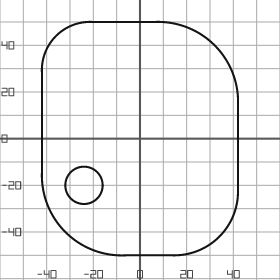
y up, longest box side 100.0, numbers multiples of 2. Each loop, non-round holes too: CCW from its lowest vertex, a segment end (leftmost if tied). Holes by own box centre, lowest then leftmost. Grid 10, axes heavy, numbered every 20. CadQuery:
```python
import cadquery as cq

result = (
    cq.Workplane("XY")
    .moveTo(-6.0, -50.0)
    .lineTo(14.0, -50.0)
    .threePointArc((34.0, -42.0), (42.0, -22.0))
    .lineTo(42.0, 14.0)
    .threePointArc((32.0, 40.0), (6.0, 50.0))
    .lineTo(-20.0, 50.0)
    .threePointArc((-36.0, 44.0), (-42.0, 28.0))
    .lineTo(-42.0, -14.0)
    .threePointArc((-32.0, -40.0), (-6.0, -50.0))
    .close()
    .moveTo(-24.0, -20.0)
    .circle(8.0)
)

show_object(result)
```